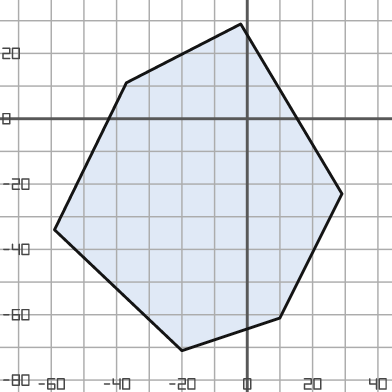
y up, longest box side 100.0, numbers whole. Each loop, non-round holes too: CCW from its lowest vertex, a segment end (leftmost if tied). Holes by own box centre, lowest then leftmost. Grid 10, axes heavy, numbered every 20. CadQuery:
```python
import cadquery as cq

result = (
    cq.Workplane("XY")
    .moveTo(-20.0, -71.0)
    .lineTo(10.0, -61.0)
    .lineTo(29.0, -23.0)
    .lineTo(-2.0, 29.0)
    .lineTo(-37.0, 11.0)
    .lineTo(-59.0, -34.0)
    .close()
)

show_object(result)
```